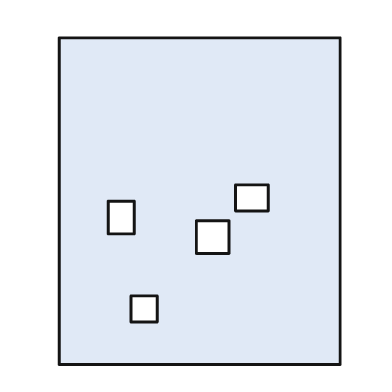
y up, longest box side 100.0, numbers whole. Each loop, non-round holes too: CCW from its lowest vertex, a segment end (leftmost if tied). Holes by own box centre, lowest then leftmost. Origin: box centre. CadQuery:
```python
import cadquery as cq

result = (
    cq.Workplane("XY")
    .moveTo(-43.0, -50.0)
    .lineTo(43.0, -50.0)
    .lineTo(43.0, 50.0)
    .lineTo(-43.0, 50.0)
    .close()
    .moveTo(-21.0, -37.0)
    .lineTo(-13.0, -37.0)
    .lineTo(-13.0, -29.0)
    .lineTo(-21.0, -29.0)
    .close()
    .moveTo(-1.0, -16.0)
    .lineTo(9.0, -16.0)
    .lineTo(9.0, -6.0)
    .lineTo(-1.0, -6.0)
    .close()
    .moveTo(-28.0, -10.0)
    .lineTo(-20.0, -10.0)
    .lineTo(-20.0, 0.0)
    .lineTo(-28.0, 0.0)
    .close()
    .moveTo(11.0, -3.0)
    .lineTo(21.0, -3.0)
    .lineTo(21.0, 5.0)
    .lineTo(11.0, 5.0)
    .close()
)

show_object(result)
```